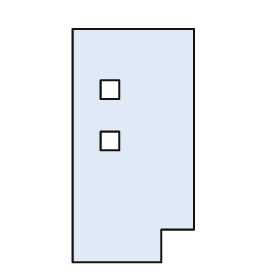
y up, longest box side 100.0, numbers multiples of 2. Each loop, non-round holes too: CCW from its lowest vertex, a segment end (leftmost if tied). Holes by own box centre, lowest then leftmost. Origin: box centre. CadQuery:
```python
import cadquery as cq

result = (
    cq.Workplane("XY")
    .moveTo(-26.0, -50.0)
    .lineTo(12.0, -50.0)
    .lineTo(12.0, -36.0)
    .lineTo(26.0, -36.0)
    .lineTo(26.0, 50.0)
    .lineTo(-26.0, 50.0)
    .close()
    .moveTo(-14.0, -2.0)
    .lineTo(-6.0, -2.0)
    .lineTo(-6.0, 6.0)
    .lineTo(-14.0, 6.0)
    .close()
    .moveTo(-14.0, 20.0)
    .lineTo(-6.0, 20.0)
    .lineTo(-6.0, 28.0)
    .lineTo(-14.0, 28.0)
    .close()
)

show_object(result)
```